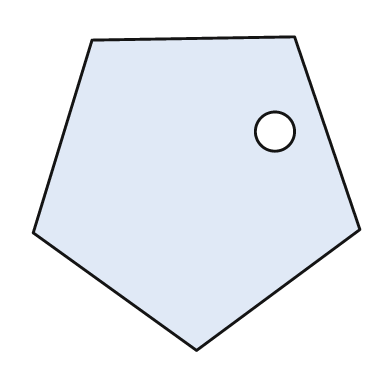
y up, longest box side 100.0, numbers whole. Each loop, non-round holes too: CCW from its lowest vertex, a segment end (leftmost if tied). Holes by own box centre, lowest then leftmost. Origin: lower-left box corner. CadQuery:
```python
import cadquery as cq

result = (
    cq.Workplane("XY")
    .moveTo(50.0, 0.0)
    .lineTo(100.0, 37.0)
    .lineTo(80.0, 96.0)
    .lineTo(18.0, 95.0)
    .lineTo(0.0, 36.0)
    .close()
    .moveTo(74.0, 67.0)
    .circle(6.0)
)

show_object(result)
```